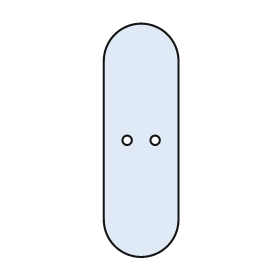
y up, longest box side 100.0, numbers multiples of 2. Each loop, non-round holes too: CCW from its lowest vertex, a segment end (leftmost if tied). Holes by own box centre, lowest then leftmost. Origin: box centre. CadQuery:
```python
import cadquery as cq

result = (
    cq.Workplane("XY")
    .moveTo(-16.0, -34.0)
    .threePointArc((0.0, -50.0), (16.0, -34.0))
    .lineTo(16.0, 34.0)
    .threePointArc((0.0, 50.0), (-16.0, 34.0))
    .close()
    .moveTo(-6.0, 0.0)
    .circle(2.0)
    .moveTo(6.0, 0.0)
    .circle(2.0)
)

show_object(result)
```